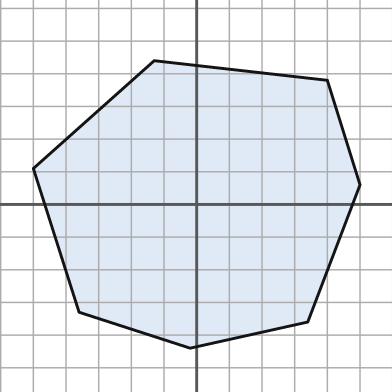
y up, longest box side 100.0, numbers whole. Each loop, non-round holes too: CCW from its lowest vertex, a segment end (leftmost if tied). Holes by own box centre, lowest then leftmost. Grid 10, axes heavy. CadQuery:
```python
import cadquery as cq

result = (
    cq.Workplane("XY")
    .moveTo(-2.0, -44.0)
    .lineTo(34.0, -36.0)
    .lineTo(50.0, 6.0)
    .lineTo(40.0, 38.0)
    .lineTo(-13.0, 44.0)
    .lineTo(-50.0, 11.0)
    .lineTo(-36.0, -33.0)
    .close()
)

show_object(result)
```